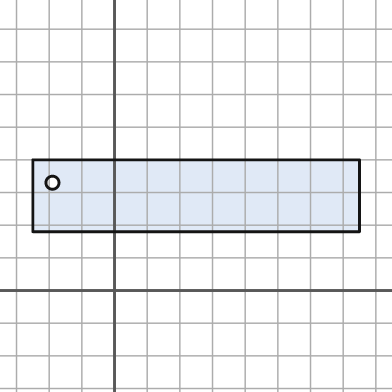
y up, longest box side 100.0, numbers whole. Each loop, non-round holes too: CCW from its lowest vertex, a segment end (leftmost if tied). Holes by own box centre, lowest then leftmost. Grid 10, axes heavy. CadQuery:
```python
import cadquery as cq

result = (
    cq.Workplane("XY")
    .moveTo(-25.0, 18.0)
    .lineTo(75.0, 18.0)
    .lineTo(75.0, 40.0)
    .lineTo(-25.0, 40.0)
    .close()
    .moveTo(-19.0, 33.0)
    .circle(2.0)
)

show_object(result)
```